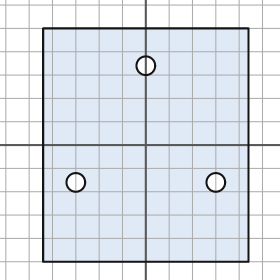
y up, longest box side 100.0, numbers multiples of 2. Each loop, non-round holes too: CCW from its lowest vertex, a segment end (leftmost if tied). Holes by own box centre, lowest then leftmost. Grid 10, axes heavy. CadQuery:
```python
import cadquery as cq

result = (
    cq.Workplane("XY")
    .moveTo(-44.0, -50.0)
    .lineTo(44.0, -50.0)
    .lineTo(44.0, 50.0)
    .lineTo(-44.0, 50.0)
    .close()
    .moveTo(-30.0, -16.0)
    .circle(4.0)
    .moveTo(30.0, -16.0)
    .circle(4.0)
    .moveTo(0.0, 34.0)
    .circle(4.0)
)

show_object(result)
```